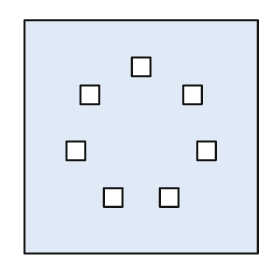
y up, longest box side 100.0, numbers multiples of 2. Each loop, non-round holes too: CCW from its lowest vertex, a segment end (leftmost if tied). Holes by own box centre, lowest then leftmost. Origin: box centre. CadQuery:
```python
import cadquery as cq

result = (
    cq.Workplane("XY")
    .moveTo(-50.0, -50.0)
    .lineTo(50.0, -50.0)
    .lineTo(50.0, 50.0)
    .lineTo(-50.0, 50.0)
    .close()
    .moveTo(-16.0, -30.0)
    .lineTo(-8.0, -30.0)
    .lineTo(-8.0, -22.0)
    .lineTo(-16.0, -22.0)
    .close()
    .moveTo(8.0, -30.0)
    .lineTo(16.0, -30.0)
    .lineTo(16.0, -22.0)
    .lineTo(8.0, -22.0)
    .close()
    .moveTo(-32.0, -10.0)
    .lineTo(-24.0, -10.0)
    .lineTo(-24.0, -2.0)
    .lineTo(-32.0, -2.0)
    .close()
    .moveTo(24.0, -10.0)
    .lineTo(32.0, -10.0)
    .lineTo(32.0, -2.0)
    .lineTo(24.0, -2.0)
    .close()
    .moveTo(-26.0, 14.0)
    .lineTo(-18.0, 14.0)
    .lineTo(-18.0, 22.0)
    .lineTo(-26.0, 22.0)
    .close()
    .moveTo(18.0, 14.0)
    .lineTo(26.0, 14.0)
    .lineTo(26.0, 22.0)
    .lineTo(18.0, 22.0)
    .close()
    .moveTo(-4.0, 26.0)
    .lineTo(4.0, 26.0)
    .lineTo(4.0, 34.0)
    .lineTo(-4.0, 34.0)
    .close()
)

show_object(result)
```